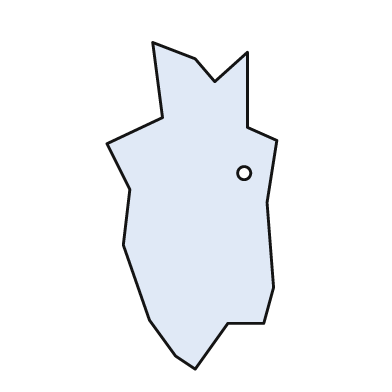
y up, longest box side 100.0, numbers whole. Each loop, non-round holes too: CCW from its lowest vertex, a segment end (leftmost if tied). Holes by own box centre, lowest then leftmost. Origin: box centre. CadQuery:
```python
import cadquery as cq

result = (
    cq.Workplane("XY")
    .moveTo(1.0, -50.0)
    .lineTo(11.0, -36.0)
    .lineTo(22.0, -36.0)
    .lineTo(25.0, -25.0)
    .lineTo(23.0, 1.0)
    .lineTo(26.0, 20.0)
    .lineTo(17.0, 24.0)
    .lineTo(17.0, 47.0)
    .lineTo(7.0, 38.0)
    .lineTo(1.0, 45.0)
    .lineTo(-12.0, 50.0)
    .lineTo(-9.0, 27.0)
    .lineTo(-26.0, 19.0)
    .lineTo(-19.0, 5.0)
    .lineTo(-21.0, -12.0)
    .lineTo(-13.0, -35.0)
    .lineTo(-5.0, -46.0)
    .close()
    .moveTo(16.0, 10.0)
    .circle(2.0)
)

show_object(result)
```